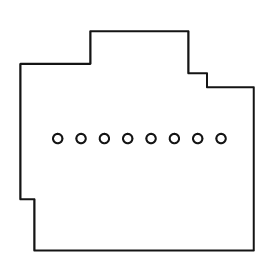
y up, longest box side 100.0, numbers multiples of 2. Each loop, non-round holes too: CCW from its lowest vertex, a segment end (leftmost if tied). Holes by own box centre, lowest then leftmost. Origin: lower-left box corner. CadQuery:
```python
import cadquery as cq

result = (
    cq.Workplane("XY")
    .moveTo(6.0, 0.0)
    .lineTo(100.0, 0.0)
    .lineTo(100.0, 70.0)
    .lineTo(80.0, 70.0)
    .lineTo(80.0, 76.0)
    .lineTo(72.0, 76.0)
    .lineTo(72.0, 94.0)
    .lineTo(30.0, 94.0)
    .lineTo(30.0, 80.0)
    .lineTo(0.0, 80.0)
    .lineTo(0.0, 22.0)
    .lineTo(6.0, 22.0)
    .close()
    .moveTo(16.0, 48.0)
    .circle(2.0)
    .moveTo(26.0, 48.0)
    .circle(2.0)
    .moveTo(36.0, 48.0)
    .circle(2.0)
    .moveTo(46.0, 48.0)
    .circle(2.0)
    .moveTo(56.0, 48.0)
    .circle(2.0)
    .moveTo(66.0, 48.0)
    .circle(2.0)
    .moveTo(76.0, 48.0)
    .circle(2.0)
    .moveTo(86.0, 48.0)
    .circle(2.0)
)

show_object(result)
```